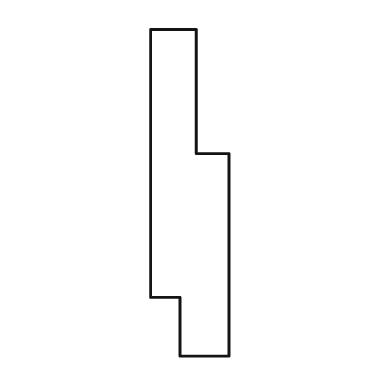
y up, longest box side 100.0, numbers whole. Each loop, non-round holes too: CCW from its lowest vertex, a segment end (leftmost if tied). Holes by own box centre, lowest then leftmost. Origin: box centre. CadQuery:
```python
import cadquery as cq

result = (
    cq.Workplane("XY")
    .moveTo(-3.0, -50.0)
    .lineTo(12.0, -50.0)
    .lineTo(12.0, 12.0)
    .lineTo(2.0, 12.0)
    .lineTo(2.0, 50.0)
    .lineTo(-12.0, 50.0)
    .lineTo(-12.0, -32.0)
    .lineTo(-3.0, -32.0)
    .close()
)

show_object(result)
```